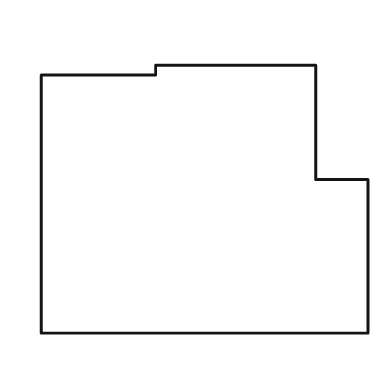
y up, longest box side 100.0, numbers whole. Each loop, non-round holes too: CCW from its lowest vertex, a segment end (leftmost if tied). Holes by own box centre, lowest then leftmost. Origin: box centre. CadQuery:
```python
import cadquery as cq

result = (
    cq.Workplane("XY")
    .moveTo(-50.0, -41.0)
    .lineTo(50.0, -41.0)
    .lineTo(50.0, 6.0)
    .lineTo(34.0, 6.0)
    .lineTo(34.0, 41.0)
    .lineTo(-15.0, 41.0)
    .lineTo(-15.0, 38.0)
    .lineTo(-50.0, 38.0)
    .close()
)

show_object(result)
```